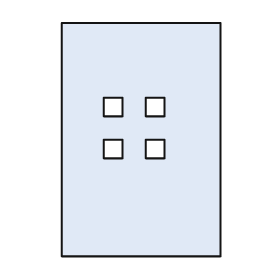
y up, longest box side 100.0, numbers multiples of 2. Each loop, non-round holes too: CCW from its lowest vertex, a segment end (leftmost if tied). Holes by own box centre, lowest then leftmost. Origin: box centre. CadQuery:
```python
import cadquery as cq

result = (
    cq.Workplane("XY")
    .moveTo(-34.0, -50.0)
    .lineTo(34.0, -50.0)
    .lineTo(34.0, 50.0)
    .lineTo(-34.0, 50.0)
    .close()
    .moveTo(-16.0, -8.0)
    .lineTo(-8.0, -8.0)
    .lineTo(-8.0, 0.0)
    .lineTo(-16.0, 0.0)
    .close()
    .moveTo(2.0, -8.0)
    .lineTo(10.0, -8.0)
    .lineTo(10.0, 0.0)
    .lineTo(2.0, 0.0)
    .close()
    .moveTo(-16.0, 10.0)
    .lineTo(-8.0, 10.0)
    .lineTo(-8.0, 18.0)
    .lineTo(-16.0, 18.0)
    .close()
    .moveTo(2.0, 10.0)
    .lineTo(10.0, 10.0)
    .lineTo(10.0, 18.0)
    .lineTo(2.0, 18.0)
    .close()
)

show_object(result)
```